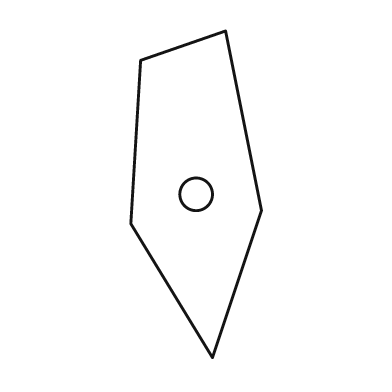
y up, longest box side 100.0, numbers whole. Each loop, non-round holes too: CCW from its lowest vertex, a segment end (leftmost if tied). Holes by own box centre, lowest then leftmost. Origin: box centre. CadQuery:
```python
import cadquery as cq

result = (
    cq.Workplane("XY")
    .moveTo(5.0, -50.0)
    .lineTo(20.0, -5.0)
    .lineTo(9.0, 50.0)
    .lineTo(-17.0, 41.0)
    .lineTo(-20.0, -9.0)
    .close()
    .moveTo(0.0, 0.0)
    .circle(5.0)
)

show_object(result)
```